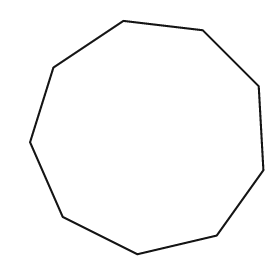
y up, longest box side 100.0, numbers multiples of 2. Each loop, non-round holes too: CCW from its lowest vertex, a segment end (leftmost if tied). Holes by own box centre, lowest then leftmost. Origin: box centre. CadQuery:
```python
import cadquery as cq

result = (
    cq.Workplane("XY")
    .moveTo(-4.0, -50.0)
    .lineTo(30.0, -42.0)
    .lineTo(50.0, -14.0)
    .lineTo(48.0, 22.0)
    .lineTo(24.0, 46.0)
    .lineTo(-10.0, 50.0)
    .lineTo(-40.0, 30.0)
    .lineTo(-50.0, -2.0)
    .lineTo(-36.0, -34.0)
    .close()
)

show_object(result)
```